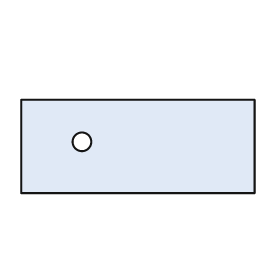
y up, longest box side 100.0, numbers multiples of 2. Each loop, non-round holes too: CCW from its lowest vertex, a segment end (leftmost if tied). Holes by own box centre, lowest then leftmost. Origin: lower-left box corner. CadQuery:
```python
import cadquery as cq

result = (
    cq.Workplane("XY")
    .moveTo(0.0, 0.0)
    .lineTo(100.0, 0.0)
    .lineTo(100.0, 40.0)
    .lineTo(0.0, 40.0)
    .close()
    .moveTo(26.0, 22.0)
    .circle(4.0)
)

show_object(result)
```